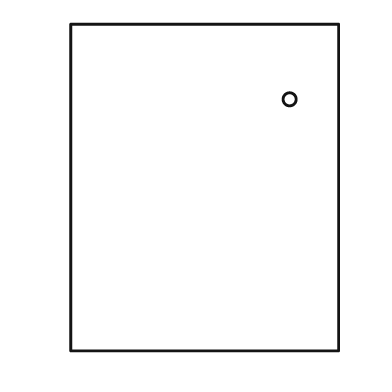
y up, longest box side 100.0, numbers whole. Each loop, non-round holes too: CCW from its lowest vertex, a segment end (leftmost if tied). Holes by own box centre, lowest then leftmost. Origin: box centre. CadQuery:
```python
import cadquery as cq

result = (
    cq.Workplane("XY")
    .moveTo(-41.0, -50.0)
    .lineTo(41.0, -50.0)
    .lineTo(41.0, 50.0)
    .lineTo(-41.0, 50.0)
    .close()
    .moveTo(26.0, 27.0)
    .circle(2.0)
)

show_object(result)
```